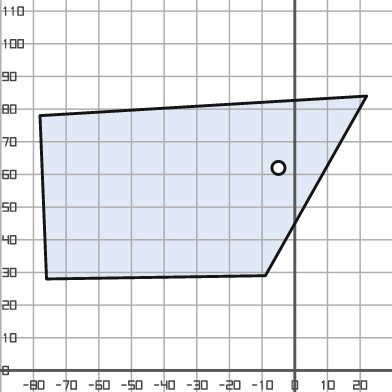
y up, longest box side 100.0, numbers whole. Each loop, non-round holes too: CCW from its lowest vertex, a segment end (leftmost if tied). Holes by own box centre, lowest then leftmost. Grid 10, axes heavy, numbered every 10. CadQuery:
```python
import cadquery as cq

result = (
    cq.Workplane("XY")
    .moveTo(-76.0, 28.0)
    .lineTo(-9.0, 29.0)
    .lineTo(22.0, 84.0)
    .lineTo(-78.0, 78.0)
    .close()
    .moveTo(-5.0, 62.0)
    .circle(2.0)
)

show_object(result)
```